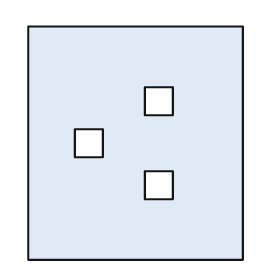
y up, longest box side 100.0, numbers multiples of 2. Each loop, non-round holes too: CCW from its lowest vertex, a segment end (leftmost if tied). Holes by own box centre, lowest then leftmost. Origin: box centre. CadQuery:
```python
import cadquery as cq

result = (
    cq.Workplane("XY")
    .moveTo(-46.0, -50.0)
    .lineTo(46.0, -50.0)
    .lineTo(46.0, 50.0)
    .lineTo(-46.0, 50.0)
    .close()
    .moveTo(4.0, -24.0)
    .lineTo(16.0, -24.0)
    .lineTo(16.0, -12.0)
    .lineTo(4.0, -12.0)
    .close()
    .moveTo(-26.0, -6.0)
    .lineTo(-14.0, -6.0)
    .lineTo(-14.0, 6.0)
    .lineTo(-26.0, 6.0)
    .close()
    .moveTo(4.0, 12.0)
    .lineTo(16.0, 12.0)
    .lineTo(16.0, 24.0)
    .lineTo(4.0, 24.0)
    .close()
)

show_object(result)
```